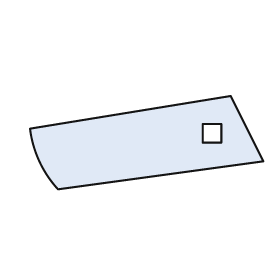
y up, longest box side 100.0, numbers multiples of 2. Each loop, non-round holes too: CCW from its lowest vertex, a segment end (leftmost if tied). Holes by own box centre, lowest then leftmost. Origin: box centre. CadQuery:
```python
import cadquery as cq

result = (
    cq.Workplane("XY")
    .moveTo(-38.0, -20.0)
    .lineTo(50.0, -8.0)
    .lineTo(36.0, 20.0)
    .lineTo(-50.0, 6.0)
    .threePointArc((-46.0, -8.0), (-38.0, -20.0))
    .close()
    .moveTo(24.0, 0.0)
    .lineTo(32.0, 0.0)
    .lineTo(32.0, 8.0)
    .lineTo(24.0, 8.0)
    .close()
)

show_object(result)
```